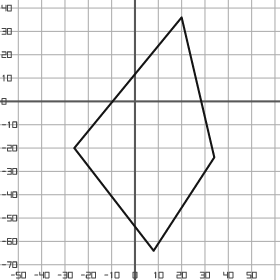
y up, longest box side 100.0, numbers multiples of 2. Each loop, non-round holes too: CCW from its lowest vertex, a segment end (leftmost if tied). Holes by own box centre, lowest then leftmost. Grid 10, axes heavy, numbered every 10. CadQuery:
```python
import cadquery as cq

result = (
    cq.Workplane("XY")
    .moveTo(8.0, -64.0)
    .lineTo(34.0, -24.0)
    .lineTo(20.0, 36.0)
    .lineTo(-26.0, -20.0)
    .close()
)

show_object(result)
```